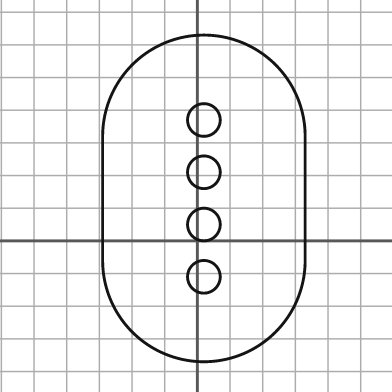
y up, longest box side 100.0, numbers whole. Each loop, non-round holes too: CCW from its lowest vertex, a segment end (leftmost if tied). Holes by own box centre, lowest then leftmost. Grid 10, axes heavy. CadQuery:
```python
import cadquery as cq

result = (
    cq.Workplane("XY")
    .moveTo(-29.0, -6.0)
    .threePointArc((2.0, -37.0), (33.0, -6.0))
    .lineTo(33.0, 32.0)
    .threePointArc((2.0, 63.0), (-29.0, 32.0))
    .close()
    .moveTo(2.0, -11.0)
    .circle(5.0)
    .moveTo(2.0, 5.0)
    .circle(5.0)
    .moveTo(2.0, 21.0)
    .circle(5.0)
    .moveTo(2.0, 37.0)
    .circle(5.0)
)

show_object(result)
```